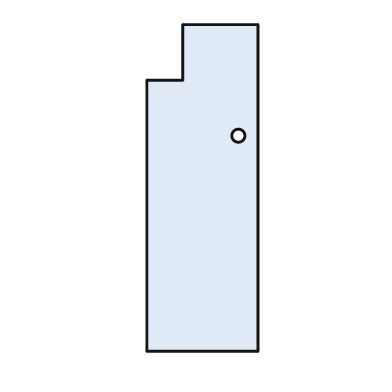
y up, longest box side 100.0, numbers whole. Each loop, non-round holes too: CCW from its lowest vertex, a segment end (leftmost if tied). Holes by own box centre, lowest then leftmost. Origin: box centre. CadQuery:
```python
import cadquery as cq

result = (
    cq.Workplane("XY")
    .moveTo(-17.0, -50.0)
    .lineTo(17.0, -50.0)
    .lineTo(17.0, 50.0)
    .lineTo(-6.0, 50.0)
    .lineTo(-6.0, 33.0)
    .lineTo(-17.0, 33.0)
    .close()
    .moveTo(11.0, 16.0)
    .circle(2.0)
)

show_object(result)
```